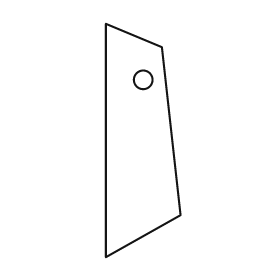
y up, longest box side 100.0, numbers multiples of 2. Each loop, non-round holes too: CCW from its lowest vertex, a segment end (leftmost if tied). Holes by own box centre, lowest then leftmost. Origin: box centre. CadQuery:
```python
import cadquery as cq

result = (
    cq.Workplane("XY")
    .moveTo(-16.0, -50.0)
    .lineTo(16.0, -32.0)
    .lineTo(8.0, 40.0)
    .lineTo(-16.0, 50.0)
    .close()
    .moveTo(0.0, 26.0)
    .circle(4.0)
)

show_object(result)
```